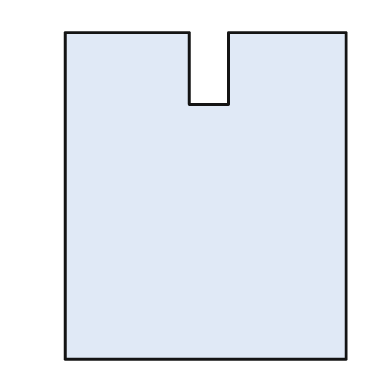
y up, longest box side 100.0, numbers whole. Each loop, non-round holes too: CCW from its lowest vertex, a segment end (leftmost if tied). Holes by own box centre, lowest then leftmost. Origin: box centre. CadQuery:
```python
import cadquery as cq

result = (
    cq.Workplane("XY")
    .moveTo(-43.0, -50.0)
    .lineTo(43.0, -50.0)
    .lineTo(43.0, 50.0)
    .lineTo(7.0, 50.0)
    .lineTo(7.0, 28.0)
    .lineTo(-5.0, 28.0)
    .lineTo(-5.0, 50.0)
    .lineTo(-43.0, 50.0)
    .close()
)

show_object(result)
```